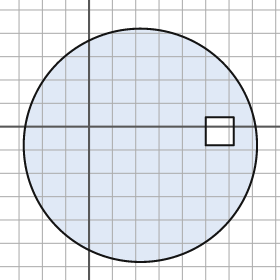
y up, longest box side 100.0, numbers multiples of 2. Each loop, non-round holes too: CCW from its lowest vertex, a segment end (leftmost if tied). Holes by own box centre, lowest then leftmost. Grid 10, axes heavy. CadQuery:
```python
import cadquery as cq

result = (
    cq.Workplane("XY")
    .moveTo(22.0, -8.0)
    .circle(50.0)
    .moveTo(50.0, -8.0)
    .lineTo(62.0, -8.0)
    .lineTo(62.0, 4.0)
    .lineTo(50.0, 4.0)
    .close()
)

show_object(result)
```